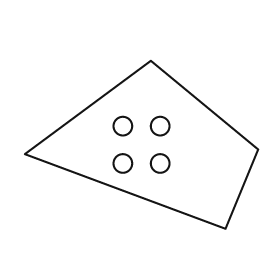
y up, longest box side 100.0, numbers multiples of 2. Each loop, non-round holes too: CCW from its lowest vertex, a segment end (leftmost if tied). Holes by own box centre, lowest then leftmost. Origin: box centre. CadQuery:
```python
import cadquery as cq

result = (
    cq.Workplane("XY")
    .moveTo(36.0, -36.0)
    .lineTo(50.0, -2.0)
    .lineTo(4.0, 36.0)
    .lineTo(-50.0, -4.0)
    .close()
    .moveTo(-8.0, -8.0)
    .circle(4.0)
    .moveTo(8.0, -8.0)
    .circle(4.0)
    .moveTo(-8.0, 8.0)
    .circle(4.0)
    .moveTo(8.0, 8.0)
    .circle(4.0)
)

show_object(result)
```